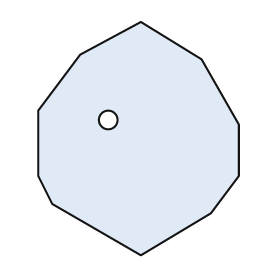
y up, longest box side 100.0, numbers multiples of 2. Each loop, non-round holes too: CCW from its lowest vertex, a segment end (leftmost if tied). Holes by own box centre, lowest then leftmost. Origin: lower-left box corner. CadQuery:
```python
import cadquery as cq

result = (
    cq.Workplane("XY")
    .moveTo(44.0, 0.0)
    .lineTo(74.0, 18.0)
    .lineTo(86.0, 34.0)
    .lineTo(86.0, 56.0)
    .lineTo(70.0, 84.0)
    .lineTo(44.0, 100.0)
    .lineTo(18.0, 86.0)
    .lineTo(0.0, 62.0)
    .lineTo(0.0, 34.0)
    .lineTo(6.0, 22.0)
    .close()
    .moveTo(30.0, 58.0)
    .circle(4.0)
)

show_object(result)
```